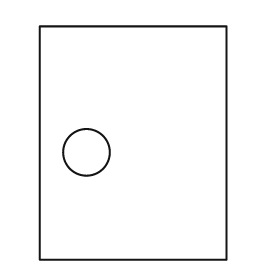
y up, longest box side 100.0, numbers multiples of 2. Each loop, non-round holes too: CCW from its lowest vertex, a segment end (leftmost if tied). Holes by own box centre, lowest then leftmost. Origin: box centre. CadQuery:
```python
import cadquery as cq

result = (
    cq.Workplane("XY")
    .moveTo(-40.0, -50.0)
    .lineTo(40.0, -50.0)
    .lineTo(40.0, 50.0)
    .lineTo(-40.0, 50.0)
    .close()
    .moveTo(-20.0, -4.0)
    .circle(10.0)
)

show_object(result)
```